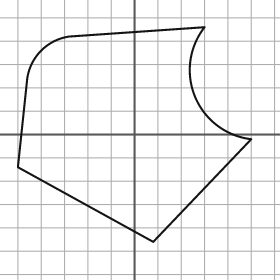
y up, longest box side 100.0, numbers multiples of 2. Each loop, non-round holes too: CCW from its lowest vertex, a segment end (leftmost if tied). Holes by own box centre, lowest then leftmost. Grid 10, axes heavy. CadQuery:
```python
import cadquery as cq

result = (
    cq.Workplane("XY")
    .moveTo(8.0, -46.0)
    .lineTo(50.0, -2.0)
    .threePointArc((26.0, 16.0), (30.0, 46.0))
    .lineTo(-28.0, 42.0)
    .threePointArc((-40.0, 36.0), (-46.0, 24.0))
    .lineTo(-50.0, -14.0)
    .close()
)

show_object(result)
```